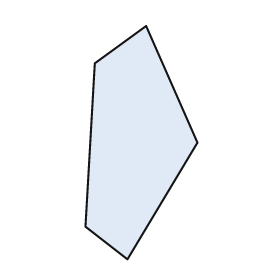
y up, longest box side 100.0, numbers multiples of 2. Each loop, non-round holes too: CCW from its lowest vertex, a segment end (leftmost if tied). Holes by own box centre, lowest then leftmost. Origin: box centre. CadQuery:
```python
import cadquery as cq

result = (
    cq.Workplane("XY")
    .moveTo(-6.0, -50.0)
    .lineTo(24.0, 0.0)
    .lineTo(2.0, 50.0)
    .lineTo(-20.0, 34.0)
    .lineTo(-24.0, -36.0)
    .close()
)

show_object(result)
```